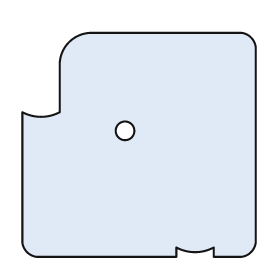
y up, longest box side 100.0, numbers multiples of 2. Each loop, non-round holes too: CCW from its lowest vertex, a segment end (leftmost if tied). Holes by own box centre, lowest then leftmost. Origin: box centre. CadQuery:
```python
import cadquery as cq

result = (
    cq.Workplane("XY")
    .moveTo(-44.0, -48.0)
    .lineTo(16.0, -48.0)
    .lineTo(16.0, -44.0)
    .threePointArc((24.0, -46.0), (32.0, -44.0))
    .lineTo(32.0, -48.0)
    .lineTo(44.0, -48.0)
    .threePointArc((48.0, -46.0), (50.0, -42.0))
    .lineTo(50.0, 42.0)
    .threePointArc((48.0, 46.0), (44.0, 48.0))
    .lineTo(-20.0, 48.0)
    .threePointArc((-30.0, 44.0), (-34.0, 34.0))
    .lineTo(-34.0, 14.0)
    .threePointArc((-42.0, 12.0), (-50.0, 14.0))
    .lineTo(-50.0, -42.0)
    .threePointArc((-48.0, -46.0), (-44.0, -48.0))
    .close()
    .moveTo(-6.0, 6.0)
    .circle(4.0)
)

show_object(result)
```